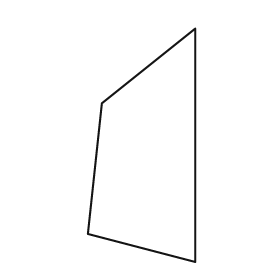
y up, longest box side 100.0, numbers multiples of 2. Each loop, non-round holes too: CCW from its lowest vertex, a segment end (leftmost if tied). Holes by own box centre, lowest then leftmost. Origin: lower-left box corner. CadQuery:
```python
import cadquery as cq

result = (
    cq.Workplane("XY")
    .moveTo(46.0, 0.0)
    .lineTo(46.0, 100.0)
    .lineTo(6.0, 68.0)
    .lineTo(0.0, 12.0)
    .close()
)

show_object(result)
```